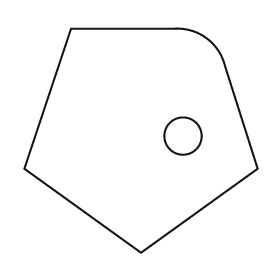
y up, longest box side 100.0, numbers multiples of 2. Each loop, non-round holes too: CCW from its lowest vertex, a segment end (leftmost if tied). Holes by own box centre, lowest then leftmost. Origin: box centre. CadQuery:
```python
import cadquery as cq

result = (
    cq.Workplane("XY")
    .moveTo(0.0, -48.0)
    .lineTo(50.0, -12.0)
    .lineTo(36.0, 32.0)
    .threePointArc((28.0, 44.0), (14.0, 48.0))
    .lineTo(-30.0, 48.0)
    .lineTo(-50.0, -12.0)
    .close()
    .moveTo(18.0, 2.0)
    .circle(8.0)
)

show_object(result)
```